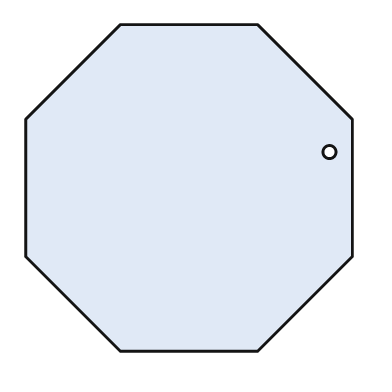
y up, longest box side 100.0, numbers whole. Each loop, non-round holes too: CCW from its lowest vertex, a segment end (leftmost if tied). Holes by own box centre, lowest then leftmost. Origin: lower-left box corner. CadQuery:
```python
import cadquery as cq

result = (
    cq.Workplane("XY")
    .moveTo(29.0, 0.0)
    .lineTo(71.0, 0.0)
    .lineTo(100.0, 29.0)
    .lineTo(100.0, 71.0)
    .lineTo(71.0, 100.0)
    .lineTo(29.0, 100.0)
    .lineTo(0.0, 71.0)
    .lineTo(0.0, 29.0)
    .close()
    .moveTo(93.0, 61.0)
    .circle(2.0)
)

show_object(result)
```